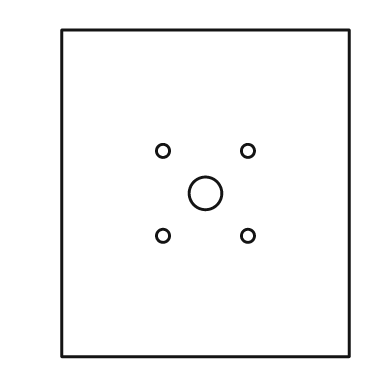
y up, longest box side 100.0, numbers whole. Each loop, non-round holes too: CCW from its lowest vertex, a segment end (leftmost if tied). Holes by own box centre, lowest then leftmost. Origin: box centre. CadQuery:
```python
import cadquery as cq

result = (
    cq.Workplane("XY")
    .moveTo(-44.0, -50.0)
    .lineTo(44.0, -50.0)
    .lineTo(44.0, 50.0)
    .lineTo(-44.0, 50.0)
    .close()
    .moveTo(-13.0, -13.0)
    .circle(2.0)
    .moveTo(13.0, -13.0)
    .circle(2.0)
    .moveTo(0.0, 0.0)
    .circle(5.0)
    .moveTo(-13.0, 13.0)
    .circle(2.0)
    .moveTo(13.0, 13.0)
    .circle(2.0)
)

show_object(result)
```